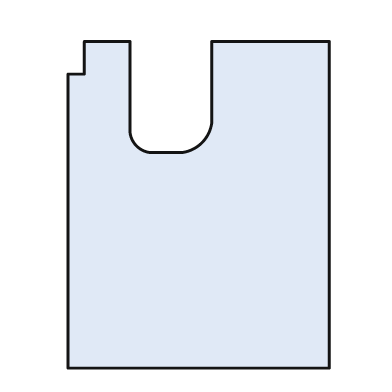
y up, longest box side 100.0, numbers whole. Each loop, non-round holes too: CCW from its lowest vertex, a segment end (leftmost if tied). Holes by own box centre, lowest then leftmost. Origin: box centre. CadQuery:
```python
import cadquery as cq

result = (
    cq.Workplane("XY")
    .moveTo(-40.0, -50.0)
    .lineTo(40.0, -50.0)
    .lineTo(40.0, 50.0)
    .lineTo(4.0, 50.0)
    .lineTo(4.0, 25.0)
    .threePointArc((1.0, 19.0), (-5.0, 16.0))
    .lineTo(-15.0, 16.0)
    .threePointArc((-19.0, 18.0), (-21.0, 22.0))
    .lineTo(-21.0, 50.0)
    .lineTo(-35.0, 50.0)
    .lineTo(-35.0, 40.0)
    .lineTo(-40.0, 40.0)
    .close()
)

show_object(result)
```